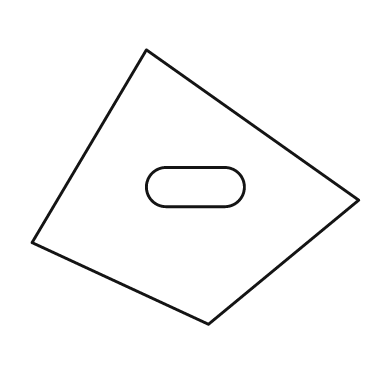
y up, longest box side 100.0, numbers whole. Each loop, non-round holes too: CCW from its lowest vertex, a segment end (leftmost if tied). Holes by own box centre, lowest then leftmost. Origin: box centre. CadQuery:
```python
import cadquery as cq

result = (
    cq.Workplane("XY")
    .moveTo(4.0, -42.0)
    .lineTo(50.0, -4.0)
    .lineTo(-15.0, 42.0)
    .lineTo(-50.0, -17.0)
    .close()
    .moveTo(-9.0, -6.0)
    .lineTo(9.0, -6.0)
    .threePointArc((15.0, 0.0), (9.0, 6.0))
    .lineTo(-9.0, 6.0)
    .threePointArc((-15.0, 0.0), (-9.0, -6.0))
    .close()
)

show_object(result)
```